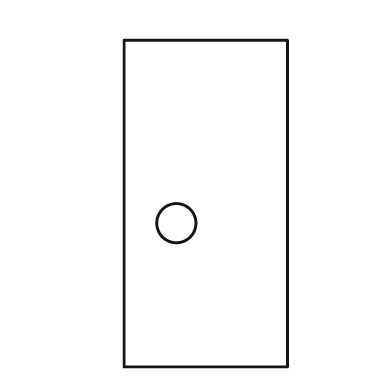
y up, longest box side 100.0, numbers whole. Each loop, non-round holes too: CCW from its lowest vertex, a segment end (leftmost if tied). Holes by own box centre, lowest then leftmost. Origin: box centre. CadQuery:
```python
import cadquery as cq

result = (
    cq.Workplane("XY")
    .moveTo(-25.0, -50.0)
    .lineTo(25.0, -50.0)
    .lineTo(25.0, 50.0)
    .lineTo(-25.0, 50.0)
    .close()
    .moveTo(-9.0, -6.0)
    .circle(6.0)
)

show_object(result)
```